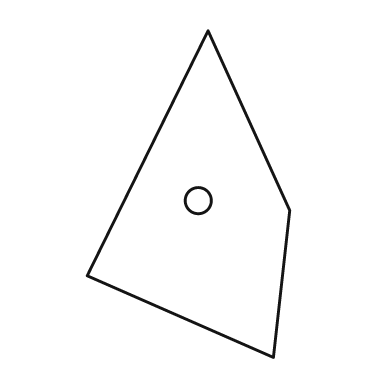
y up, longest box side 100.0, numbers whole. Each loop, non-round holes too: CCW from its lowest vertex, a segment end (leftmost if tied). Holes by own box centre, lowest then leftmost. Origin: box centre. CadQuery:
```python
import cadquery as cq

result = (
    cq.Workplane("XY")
    .moveTo(26.0, -50.0)
    .lineTo(31.0, -5.0)
    .lineTo(6.0, 50.0)
    .lineTo(-31.0, -25.0)
    .close()
    .moveTo(3.0, -2.0)
    .circle(4.0)
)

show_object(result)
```